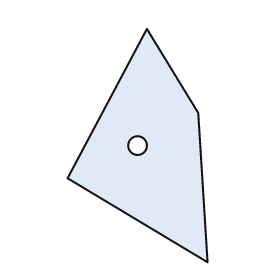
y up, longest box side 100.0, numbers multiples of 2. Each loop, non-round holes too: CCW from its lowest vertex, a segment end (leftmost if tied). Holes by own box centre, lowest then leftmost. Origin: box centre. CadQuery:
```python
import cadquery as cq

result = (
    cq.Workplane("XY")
    .moveTo(30.0, -50.0)
    .lineTo(26.0, 14.0)
    .lineTo(4.0, 50.0)
    .lineTo(-30.0, -14.0)
    .close()
    .moveTo(0.0, 0.0)
    .circle(4.0)
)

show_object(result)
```